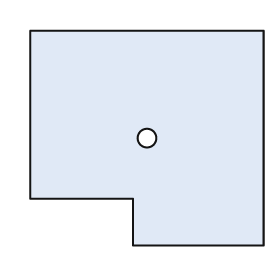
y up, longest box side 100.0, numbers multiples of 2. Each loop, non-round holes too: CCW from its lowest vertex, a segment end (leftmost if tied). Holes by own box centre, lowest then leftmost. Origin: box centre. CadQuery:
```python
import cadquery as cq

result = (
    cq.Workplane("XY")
    .moveTo(-6.0, -46.0)
    .lineTo(50.0, -46.0)
    .lineTo(50.0, 46.0)
    .lineTo(-50.0, 46.0)
    .lineTo(-50.0, -26.0)
    .lineTo(-6.0, -26.0)
    .close()
    .moveTo(0.0, 0.0)
    .circle(4.0)
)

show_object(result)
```